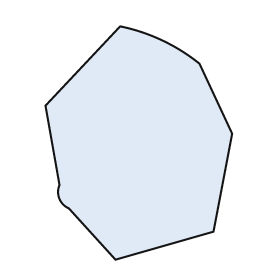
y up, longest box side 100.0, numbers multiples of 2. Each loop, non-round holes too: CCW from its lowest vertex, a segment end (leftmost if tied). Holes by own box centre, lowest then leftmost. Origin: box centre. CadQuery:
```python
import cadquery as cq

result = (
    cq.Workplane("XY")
    .moveTo(-10.0, -50.0)
    .lineTo(32.0, -38.0)
    .lineTo(40.0, 4.0)
    .lineTo(26.0, 34.0)
    .threePointArc((10.0, 44.0), (-8.0, 50.0))
    .lineTo(-40.0, 16.0)
    .lineTo(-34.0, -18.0)
    .threePointArc((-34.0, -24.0), (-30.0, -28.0))
    .close()
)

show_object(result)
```